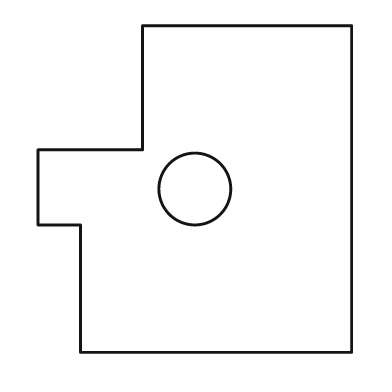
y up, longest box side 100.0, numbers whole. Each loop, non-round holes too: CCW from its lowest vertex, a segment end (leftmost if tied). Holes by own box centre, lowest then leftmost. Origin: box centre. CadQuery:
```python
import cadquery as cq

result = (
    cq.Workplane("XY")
    .moveTo(-35.0, -50.0)
    .lineTo(48.0, -50.0)
    .lineTo(48.0, 50.0)
    .lineTo(-16.0, 50.0)
    .lineTo(-16.0, 12.0)
    .lineTo(-48.0, 12.0)
    .lineTo(-48.0, -11.0)
    .lineTo(-35.0, -11.0)
    .close()
    .moveTo(0.0, 0.0)
    .circle(11.0)
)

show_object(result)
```